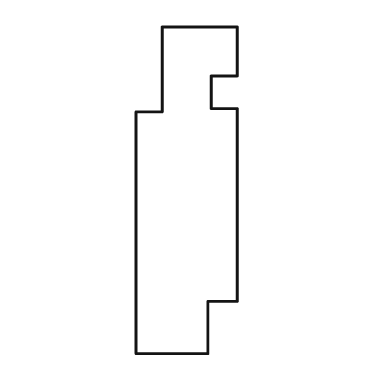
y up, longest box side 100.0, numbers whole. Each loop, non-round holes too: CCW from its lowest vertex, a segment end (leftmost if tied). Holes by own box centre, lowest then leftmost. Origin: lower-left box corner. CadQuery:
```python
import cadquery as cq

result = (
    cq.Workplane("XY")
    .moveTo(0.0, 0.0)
    .lineTo(22.0, 0.0)
    .lineTo(22.0, 16.0)
    .lineTo(31.0, 16.0)
    .lineTo(31.0, 75.0)
    .lineTo(23.0, 75.0)
    .lineTo(23.0, 85.0)
    .lineTo(31.0, 85.0)
    .lineTo(31.0, 100.0)
    .lineTo(8.0, 100.0)
    .lineTo(8.0, 74.0)
    .lineTo(0.0, 74.0)
    .close()
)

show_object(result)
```